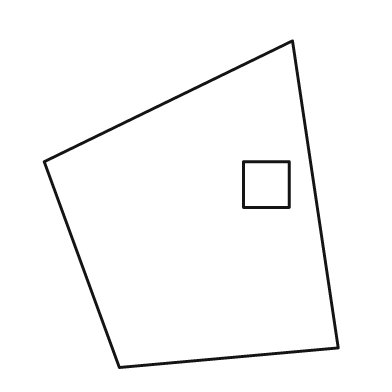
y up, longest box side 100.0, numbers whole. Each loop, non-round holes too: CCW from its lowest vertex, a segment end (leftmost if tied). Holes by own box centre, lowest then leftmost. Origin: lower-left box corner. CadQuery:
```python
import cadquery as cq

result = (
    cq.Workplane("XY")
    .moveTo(23.0, 0.0)
    .lineTo(90.0, 6.0)
    .lineTo(76.0, 100.0)
    .lineTo(0.0, 63.0)
    .close()
    .moveTo(61.0, 49.0)
    .lineTo(75.0, 49.0)
    .lineTo(75.0, 63.0)
    .lineTo(61.0, 63.0)
    .close()
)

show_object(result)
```